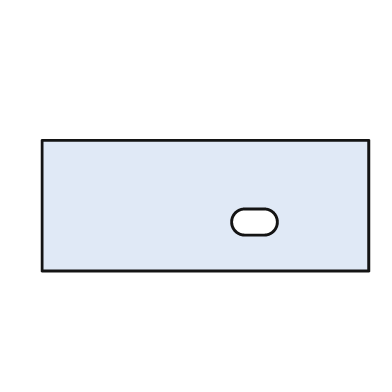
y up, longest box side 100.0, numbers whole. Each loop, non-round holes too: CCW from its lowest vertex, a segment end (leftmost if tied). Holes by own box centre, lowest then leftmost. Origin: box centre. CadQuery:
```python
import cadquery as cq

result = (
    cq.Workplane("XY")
    .moveTo(-50.0, -20.0)
    .lineTo(50.0, -20.0)
    .lineTo(50.0, 20.0)
    .lineTo(-50.0, 20.0)
    .close()
    .moveTo(12.0, -9.0)
    .lineTo(18.0, -9.0)
    .threePointArc((22.0, -5.0), (18.0, -1.0))
    .lineTo(12.0, -1.0)
    .threePointArc((8.0, -5.0), (12.0, -9.0))
    .close()
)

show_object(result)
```